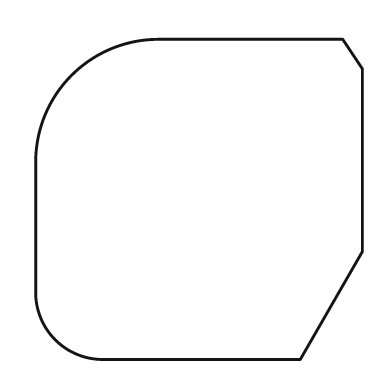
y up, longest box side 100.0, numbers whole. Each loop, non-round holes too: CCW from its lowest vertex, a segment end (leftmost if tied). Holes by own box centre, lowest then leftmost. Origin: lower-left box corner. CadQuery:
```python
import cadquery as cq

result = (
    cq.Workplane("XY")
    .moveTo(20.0, 0.0)
    .lineTo(81.0, 0.0)
    .lineTo(100.0, 33.0)
    .lineTo(100.0, 89.0)
    .lineTo(94.0, 98.0)
    .lineTo(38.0, 98.0)
    .threePointArc((11.0, 87.0), (0.0, 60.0))
    .lineTo(0.0, 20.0)
    .threePointArc((6.0, 6.0), (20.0, 0.0))
    .close()
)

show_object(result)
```